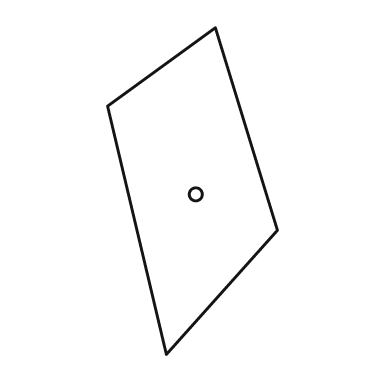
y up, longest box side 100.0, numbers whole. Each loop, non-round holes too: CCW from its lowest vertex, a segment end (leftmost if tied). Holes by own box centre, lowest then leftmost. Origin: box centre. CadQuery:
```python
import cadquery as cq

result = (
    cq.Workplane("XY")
    .moveTo(-8.0, -50.0)
    .lineTo(26.0, -12.0)
    .lineTo(7.0, 50.0)
    .lineTo(-26.0, 26.0)
    .close()
    .moveTo(1.0, -1.0)
    .circle(2.0)
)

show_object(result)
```